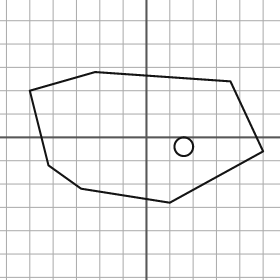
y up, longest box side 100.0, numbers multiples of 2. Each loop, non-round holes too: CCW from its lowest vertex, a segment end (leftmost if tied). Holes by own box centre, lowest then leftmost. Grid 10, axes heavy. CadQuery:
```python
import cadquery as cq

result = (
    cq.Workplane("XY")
    .moveTo(10.0, -28.0)
    .lineTo(50.0, -6.0)
    .lineTo(36.0, 24.0)
    .lineTo(-22.0, 28.0)
    .lineTo(-50.0, 20.0)
    .lineTo(-42.0, -12.0)
    .lineTo(-28.0, -22.0)
    .close()
    .moveTo(16.0, -4.0)
    .circle(4.0)
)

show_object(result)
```